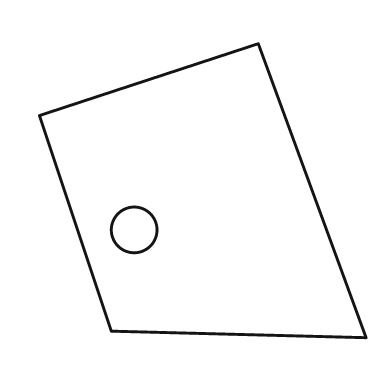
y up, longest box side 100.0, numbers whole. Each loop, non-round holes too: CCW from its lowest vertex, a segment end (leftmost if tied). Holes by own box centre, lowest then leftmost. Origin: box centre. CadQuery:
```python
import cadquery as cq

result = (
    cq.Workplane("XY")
    .moveTo(50.0, -45.0)
    .lineTo(17.0, 45.0)
    .lineTo(-50.0, 23.0)
    .lineTo(-28.0, -43.0)
    .close()
    .moveTo(-21.0, -12.0)
    .circle(7.0)
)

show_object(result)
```